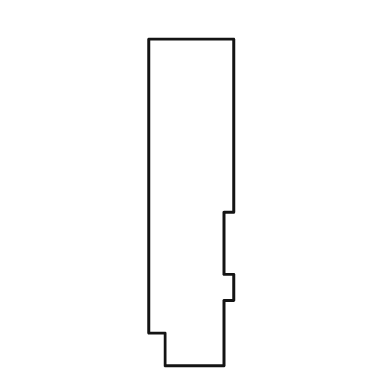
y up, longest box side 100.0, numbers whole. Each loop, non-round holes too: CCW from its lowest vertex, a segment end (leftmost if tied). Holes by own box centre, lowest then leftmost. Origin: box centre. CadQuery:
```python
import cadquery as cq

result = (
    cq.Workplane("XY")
    .moveTo(-8.0, -50.0)
    .lineTo(10.0, -50.0)
    .lineTo(10.0, -30.0)
    .lineTo(13.0, -30.0)
    .lineTo(13.0, -22.0)
    .lineTo(10.0, -22.0)
    .lineTo(10.0, -3.0)
    .lineTo(13.0, -3.0)
    .lineTo(13.0, 50.0)
    .lineTo(-13.0, 50.0)
    .lineTo(-13.0, -40.0)
    .lineTo(-8.0, -40.0)
    .close()
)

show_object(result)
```